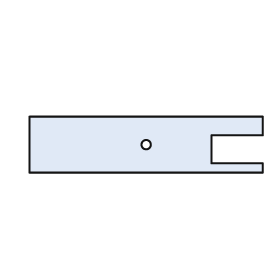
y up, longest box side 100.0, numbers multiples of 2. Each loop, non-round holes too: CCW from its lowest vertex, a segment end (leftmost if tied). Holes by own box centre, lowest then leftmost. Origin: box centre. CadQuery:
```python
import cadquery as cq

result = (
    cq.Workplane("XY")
    .moveTo(-50.0, -12.0)
    .lineTo(50.0, -12.0)
    .lineTo(50.0, -8.0)
    .lineTo(28.0, -8.0)
    .lineTo(28.0, 4.0)
    .lineTo(50.0, 4.0)
    .lineTo(50.0, 12.0)
    .lineTo(-50.0, 12.0)
    .close()
    .moveTo(0.0, 0.0)
    .circle(2.0)
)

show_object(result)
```